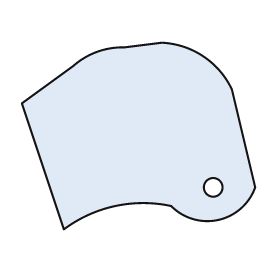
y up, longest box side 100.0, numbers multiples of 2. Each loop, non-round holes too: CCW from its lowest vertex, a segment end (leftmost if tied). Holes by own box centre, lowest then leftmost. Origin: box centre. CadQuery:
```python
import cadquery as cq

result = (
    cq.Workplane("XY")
    .moveTo(-32.0, -40.0)
    .threePointArc((-10.0, -30.0), (14.0, -30.0))
    .threePointArc((34.0, -36.0), (50.0, -22.0))
    .lineTo(40.0, 20.0)
    .threePointArc((28.0, 34.0), (10.0, 40.0))
    .lineTo(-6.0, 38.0)
    .threePointArc((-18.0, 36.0), (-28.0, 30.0))
    .lineTo(-50.0, 14.0)
    .close()
    .moveTo(32.0, -22.0)
    .circle(4.0)
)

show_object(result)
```